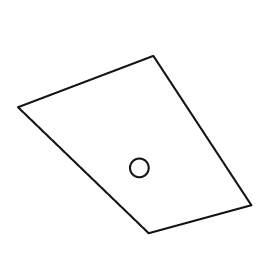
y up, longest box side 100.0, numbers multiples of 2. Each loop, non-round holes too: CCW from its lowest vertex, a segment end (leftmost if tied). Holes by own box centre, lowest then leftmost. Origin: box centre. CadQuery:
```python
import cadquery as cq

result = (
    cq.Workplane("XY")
    .moveTo(6.0, -38.0)
    .lineTo(50.0, -26.0)
    .lineTo(8.0, 38.0)
    .lineTo(-50.0, 16.0)
    .close()
    .moveTo(2.0, -10.0)
    .circle(4.0)
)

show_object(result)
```